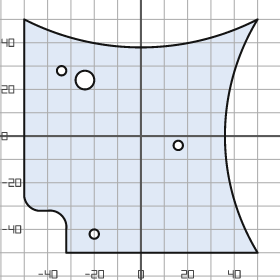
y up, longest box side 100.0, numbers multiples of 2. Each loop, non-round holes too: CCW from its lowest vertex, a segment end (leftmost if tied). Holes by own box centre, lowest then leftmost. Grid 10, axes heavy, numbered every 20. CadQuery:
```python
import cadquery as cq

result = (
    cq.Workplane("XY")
    .moveTo(-32.0, -50.0)
    .lineTo(50.0, -50.0)
    .threePointArc((36.0, 0.0), (50.0, 50.0))
    .threePointArc((0.0, 38.0), (-50.0, 50.0))
    .lineTo(-50.0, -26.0)
    .threePointArc((-48.0, -30.0), (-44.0, -32.0))
    .lineTo(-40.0, -32.0)
    .threePointArc((-34.0, -34.0), (-32.0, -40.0))
    .close()
    .moveTo(-20.0, -42.0)
    .circle(2.0)
    .moveTo(16.0, -4.0)
    .circle(2.0)
    .moveTo(-24.0, 24.0)
    .circle(4.0)
    .moveTo(-34.0, 28.0)
    .circle(2.0)
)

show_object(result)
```